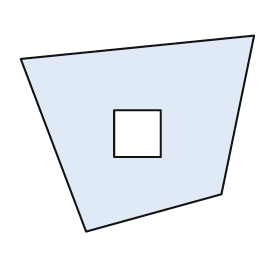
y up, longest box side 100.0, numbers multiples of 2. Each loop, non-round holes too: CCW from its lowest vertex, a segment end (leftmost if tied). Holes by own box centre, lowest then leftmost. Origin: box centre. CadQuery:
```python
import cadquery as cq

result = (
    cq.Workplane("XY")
    .moveTo(-22.0, -42.0)
    .lineTo(36.0, -26.0)
    .lineTo(50.0, 42.0)
    .lineTo(-50.0, 32.0)
    .close()
    .moveTo(-10.0, -10.0)
    .lineTo(10.0, -10.0)
    .lineTo(10.0, 10.0)
    .lineTo(-10.0, 10.0)
    .close()
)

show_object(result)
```